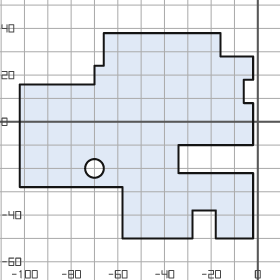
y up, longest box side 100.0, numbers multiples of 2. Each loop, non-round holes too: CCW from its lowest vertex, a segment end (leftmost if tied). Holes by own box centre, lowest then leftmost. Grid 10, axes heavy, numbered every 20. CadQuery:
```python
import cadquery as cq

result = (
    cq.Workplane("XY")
    .moveTo(-58.0, -50.0)
    .lineTo(-28.0, -50.0)
    .lineTo(-28.0, -38.0)
    .lineTo(-18.0, -38.0)
    .lineTo(-18.0, -50.0)
    .lineTo(-2.0, -50.0)
    .lineTo(-2.0, -22.0)
    .lineTo(-34.0, -22.0)
    .lineTo(-34.0, -10.0)
    .lineTo(-2.0, -10.0)
    .lineTo(-2.0, 8.0)
    .lineTo(-6.0, 8.0)
    .lineTo(-6.0, 18.0)
    .lineTo(-2.0, 18.0)
    .lineTo(-2.0, 28.0)
    .lineTo(-16.0, 28.0)
    .lineTo(-16.0, 38.0)
    .lineTo(-66.0, 38.0)
    .lineTo(-66.0, 24.0)
    .lineTo(-70.0, 24.0)
    .lineTo(-70.0, 16.0)
    .lineTo(-102.0, 16.0)
    .lineTo(-102.0, -28.0)
    .lineTo(-58.0, -28.0)
    .close()
    .moveTo(-70.0, -20.0)
    .circle(4.0)
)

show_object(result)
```